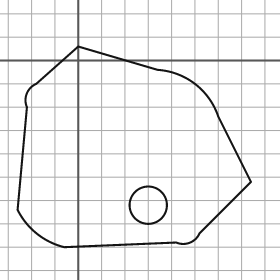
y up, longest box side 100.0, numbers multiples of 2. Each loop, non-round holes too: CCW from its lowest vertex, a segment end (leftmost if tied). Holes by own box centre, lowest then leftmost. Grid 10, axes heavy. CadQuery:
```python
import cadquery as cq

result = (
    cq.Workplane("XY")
    .moveTo(-6.0, -80.0)
    .lineTo(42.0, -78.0)
    .threePointArc((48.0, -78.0), (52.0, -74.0))
    .lineTo(74.0, -52.0)
    .lineTo(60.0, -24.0)
    .threePointArc((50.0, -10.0), (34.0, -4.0))
    .lineTo(0.0, 6.0)
    .lineTo(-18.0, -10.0)
    .threePointArc((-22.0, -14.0), (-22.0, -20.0))
    .lineTo(-26.0, -64.0)
    .threePointArc((-18.0, -74.0), (-6.0, -80.0))
    .close()
    .moveTo(30.0, -62.0)
    .circle(8.0)
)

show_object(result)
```